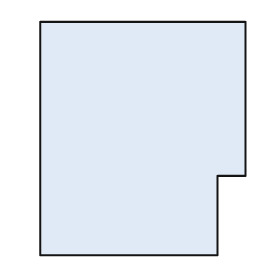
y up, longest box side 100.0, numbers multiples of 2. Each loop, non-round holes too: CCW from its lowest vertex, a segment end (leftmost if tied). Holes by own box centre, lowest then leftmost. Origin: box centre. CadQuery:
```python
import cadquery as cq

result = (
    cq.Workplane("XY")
    .moveTo(-44.0, -50.0)
    .lineTo(32.0, -50.0)
    .lineTo(32.0, -16.0)
    .lineTo(44.0, -16.0)
    .lineTo(44.0, 50.0)
    .lineTo(-44.0, 50.0)
    .close()
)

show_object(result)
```